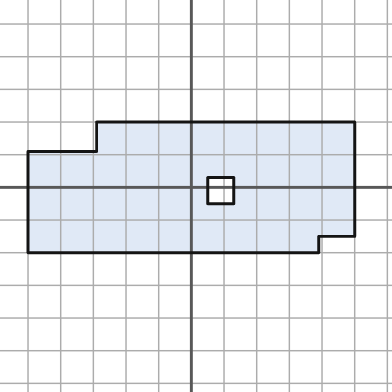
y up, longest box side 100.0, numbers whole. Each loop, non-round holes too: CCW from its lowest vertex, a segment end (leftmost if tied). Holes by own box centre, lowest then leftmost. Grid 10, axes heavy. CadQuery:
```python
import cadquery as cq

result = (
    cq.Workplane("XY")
    .moveTo(-50.0, -20.0)
    .lineTo(39.0, -20.0)
    .lineTo(39.0, -15.0)
    .lineTo(50.0, -15.0)
    .lineTo(50.0, 20.0)
    .lineTo(-29.0, 20.0)
    .lineTo(-29.0, 11.0)
    .lineTo(-50.0, 11.0)
    .close()
    .moveTo(5.0, -5.0)
    .lineTo(13.0, -5.0)
    .lineTo(13.0, 3.0)
    .lineTo(5.0, 3.0)
    .close()
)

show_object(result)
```